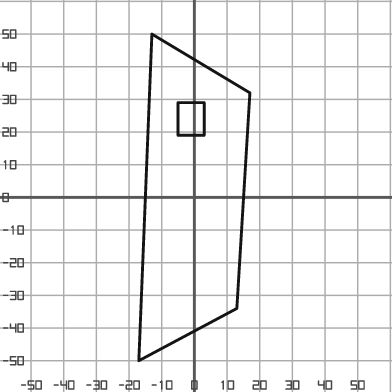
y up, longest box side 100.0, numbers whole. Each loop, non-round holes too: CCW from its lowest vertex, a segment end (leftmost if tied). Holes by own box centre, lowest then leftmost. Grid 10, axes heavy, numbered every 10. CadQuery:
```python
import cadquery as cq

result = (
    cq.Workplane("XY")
    .moveTo(-17.0, -50.0)
    .lineTo(13.0, -34.0)
    .lineTo(17.0, 32.0)
    .lineTo(-13.0, 50.0)
    .close()
    .moveTo(-5.0, 19.0)
    .lineTo(3.0, 19.0)
    .lineTo(3.0, 29.0)
    .lineTo(-5.0, 29.0)
    .close()
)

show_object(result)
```